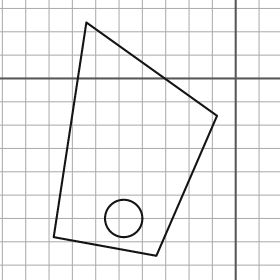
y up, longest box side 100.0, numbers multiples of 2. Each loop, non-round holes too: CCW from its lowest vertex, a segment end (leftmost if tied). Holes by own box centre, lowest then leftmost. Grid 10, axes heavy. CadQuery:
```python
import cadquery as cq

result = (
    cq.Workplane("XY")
    .moveTo(-34.0, -76.0)
    .lineTo(-8.0, -16.0)
    .lineTo(-64.0, 24.0)
    .lineTo(-78.0, -68.0)
    .close()
    .moveTo(-48.0, -60.0)
    .circle(8.0)
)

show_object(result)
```